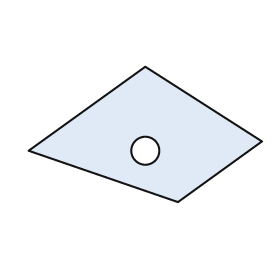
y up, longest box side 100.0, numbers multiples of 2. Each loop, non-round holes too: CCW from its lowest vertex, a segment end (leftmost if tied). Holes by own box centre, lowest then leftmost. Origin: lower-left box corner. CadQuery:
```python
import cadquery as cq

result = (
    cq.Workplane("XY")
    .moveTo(64.0, 0.0)
    .lineTo(100.0, 26.0)
    .lineTo(50.0, 58.0)
    .lineTo(0.0, 22.0)
    .close()
    .moveTo(50.0, 22.0)
    .circle(6.0)
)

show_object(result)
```